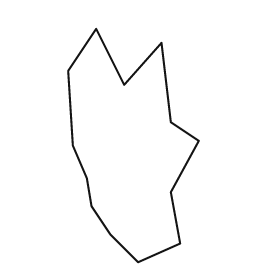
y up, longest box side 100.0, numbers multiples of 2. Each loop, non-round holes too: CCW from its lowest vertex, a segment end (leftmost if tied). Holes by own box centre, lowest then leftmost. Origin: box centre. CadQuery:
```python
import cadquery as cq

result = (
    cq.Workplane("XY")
    .moveTo(2.0, -50.0)
    .lineTo(20.0, -42.0)
    .lineTo(16.0, -20.0)
    .lineTo(28.0, 2.0)
    .lineTo(16.0, 10.0)
    .lineTo(12.0, 44.0)
    .lineTo(-4.0, 26.0)
    .lineTo(-16.0, 50.0)
    .lineTo(-28.0, 32.0)
    .lineTo(-26.0, 0.0)
    .lineTo(-20.0, -14.0)
    .lineTo(-18.0, -26.0)
    .lineTo(-10.0, -38.0)
    .close()
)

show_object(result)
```